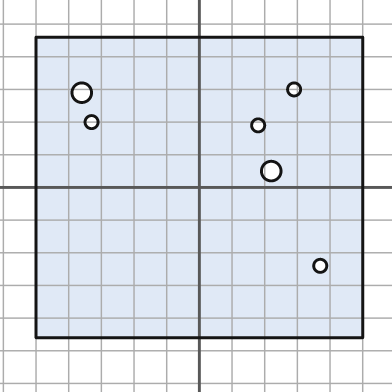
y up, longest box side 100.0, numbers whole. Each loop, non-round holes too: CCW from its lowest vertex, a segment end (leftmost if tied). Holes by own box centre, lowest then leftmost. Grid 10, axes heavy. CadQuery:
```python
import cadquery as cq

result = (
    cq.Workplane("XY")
    .moveTo(-50.0, -46.0)
    .lineTo(50.0, -46.0)
    .lineTo(50.0, 46.0)
    .lineTo(-50.0, 46.0)
    .close()
    .moveTo(37.0, -24.0)
    .circle(2.0)
    .moveTo(22.0, 5.0)
    .circle(3.0)
    .moveTo(18.0, 19.0)
    .circle(2.0)
    .moveTo(-33.0, 20.0)
    .circle(2.0)
    .moveTo(-36.0, 29.0)
    .circle(3.0)
    .moveTo(29.0, 30.0)
    .circle(2.0)
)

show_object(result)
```